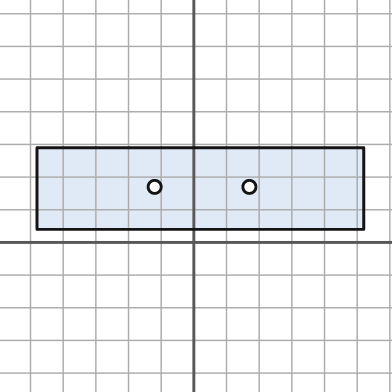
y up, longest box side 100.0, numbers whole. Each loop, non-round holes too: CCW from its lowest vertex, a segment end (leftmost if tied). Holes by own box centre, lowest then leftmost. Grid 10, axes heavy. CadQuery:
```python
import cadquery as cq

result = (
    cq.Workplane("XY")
    .moveTo(-48.0, 4.0)
    .lineTo(52.0, 4.0)
    .lineTo(52.0, 29.0)
    .lineTo(-48.0, 29.0)
    .close()
    .moveTo(-12.0, 17.0)
    .circle(2.0)
    .moveTo(17.0, 17.0)
    .circle(2.0)
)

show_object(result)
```